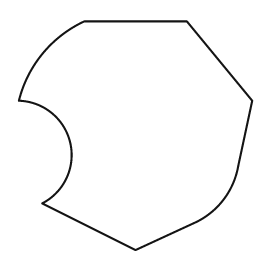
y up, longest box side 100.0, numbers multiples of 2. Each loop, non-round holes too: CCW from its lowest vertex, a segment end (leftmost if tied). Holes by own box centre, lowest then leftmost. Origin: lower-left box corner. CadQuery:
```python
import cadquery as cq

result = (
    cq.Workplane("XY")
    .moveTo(50.0, 0.0)
    .lineTo(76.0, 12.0)
    .threePointArc((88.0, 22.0), (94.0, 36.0))
    .lineTo(100.0, 64.0)
    .lineTo(72.0, 98.0)
    .lineTo(28.0, 98.0)
    .threePointArc((10.0, 84.0), (0.0, 64.0))
    .threePointArc((22.0, 46.0), (10.0, 20.0))
    .close()
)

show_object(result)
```